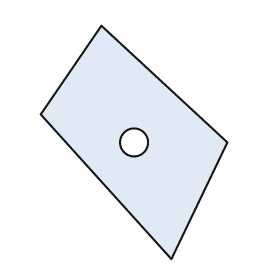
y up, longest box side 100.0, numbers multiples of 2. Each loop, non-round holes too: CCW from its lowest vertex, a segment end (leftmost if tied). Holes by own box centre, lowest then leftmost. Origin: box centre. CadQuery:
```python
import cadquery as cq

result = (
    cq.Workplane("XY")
    .moveTo(16.0, -50.0)
    .lineTo(40.0, 0.0)
    .lineTo(-14.0, 50.0)
    .lineTo(-40.0, 12.0)
    .close()
    .moveTo(0.0, 0.0)
    .circle(6.0)
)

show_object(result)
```